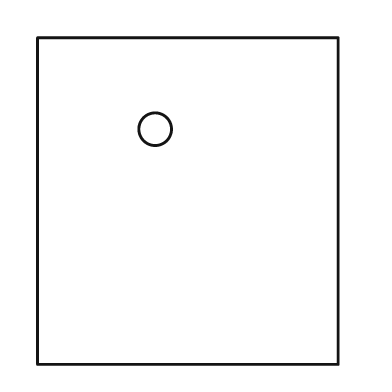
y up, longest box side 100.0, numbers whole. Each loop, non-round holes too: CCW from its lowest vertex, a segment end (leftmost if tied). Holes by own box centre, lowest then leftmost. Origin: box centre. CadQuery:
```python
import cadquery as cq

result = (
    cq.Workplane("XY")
    .moveTo(-46.0, -50.0)
    .lineTo(46.0, -50.0)
    .lineTo(46.0, 50.0)
    .lineTo(-46.0, 50.0)
    .close()
    .moveTo(-10.0, 22.0)
    .circle(5.0)
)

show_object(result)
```